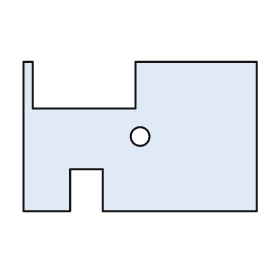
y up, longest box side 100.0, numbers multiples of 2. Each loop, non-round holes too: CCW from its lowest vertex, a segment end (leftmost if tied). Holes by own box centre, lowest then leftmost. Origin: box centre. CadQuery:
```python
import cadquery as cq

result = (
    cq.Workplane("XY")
    .moveTo(-50.0, -32.0)
    .lineTo(-30.0, -32.0)
    .lineTo(-30.0, -14.0)
    .lineTo(-16.0, -14.0)
    .lineTo(-16.0, -32.0)
    .lineTo(50.0, -32.0)
    .lineTo(50.0, 32.0)
    .lineTo(-2.0, 32.0)
    .lineTo(-2.0, 12.0)
    .lineTo(-46.0, 12.0)
    .lineTo(-46.0, 32.0)
    .lineTo(-50.0, 32.0)
    .close()
    .moveTo(0.0, 0.0)
    .circle(4.0)
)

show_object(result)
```